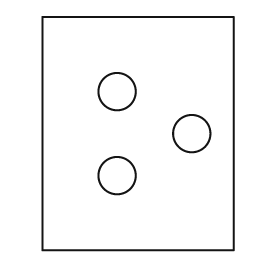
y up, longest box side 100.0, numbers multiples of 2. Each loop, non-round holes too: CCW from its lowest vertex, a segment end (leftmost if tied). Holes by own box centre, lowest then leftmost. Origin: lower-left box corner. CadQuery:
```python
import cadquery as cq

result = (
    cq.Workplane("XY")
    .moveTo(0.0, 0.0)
    .lineTo(82.0, 0.0)
    .lineTo(82.0, 100.0)
    .lineTo(0.0, 100.0)
    .close()
    .moveTo(32.0, 32.0)
    .circle(8.0)
    .moveTo(64.0, 50.0)
    .circle(8.0)
    .moveTo(32.0, 68.0)
    .circle(8.0)
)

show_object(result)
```